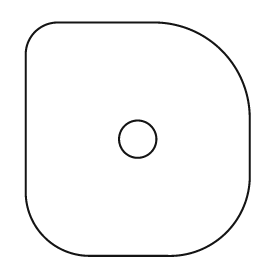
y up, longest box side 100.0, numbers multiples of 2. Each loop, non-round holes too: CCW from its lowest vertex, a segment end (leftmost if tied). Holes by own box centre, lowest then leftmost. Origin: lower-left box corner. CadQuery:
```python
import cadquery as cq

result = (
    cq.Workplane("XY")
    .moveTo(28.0, 0.0)
    .lineTo(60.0, 0.0)
    .threePointArc((86.0, 10.0), (96.0, 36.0))
    .lineTo(96.0, 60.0)
    .threePointArc((84.0, 88.0), (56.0, 100.0))
    .lineTo(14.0, 100.0)
    .threePointArc((4.0, 96.0), (0.0, 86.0))
    .lineTo(0.0, 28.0)
    .threePointArc((8.0, 8.0), (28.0, 0.0))
    .close()
    .moveTo(48.0, 50.0)
    .circle(8.0)
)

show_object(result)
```